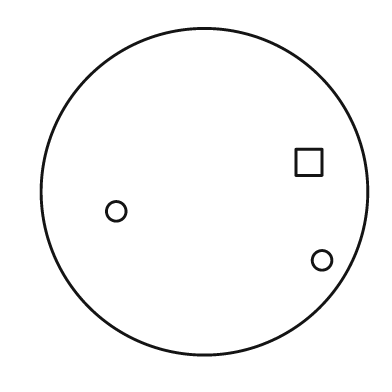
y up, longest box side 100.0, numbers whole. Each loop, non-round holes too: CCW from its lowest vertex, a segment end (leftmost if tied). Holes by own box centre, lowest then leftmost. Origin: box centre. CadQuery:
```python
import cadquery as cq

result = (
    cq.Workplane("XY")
    .moveTo(0.0, 0.0)
    .circle(50.0)
    .moveTo(36.0, -21.0)
    .circle(3.0)
    .moveTo(-27.0, -6.0)
    .circle(3.0)
    .moveTo(28.0, 5.0)
    .lineTo(36.0, 5.0)
    .lineTo(36.0, 13.0)
    .lineTo(28.0, 13.0)
    .close()
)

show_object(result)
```